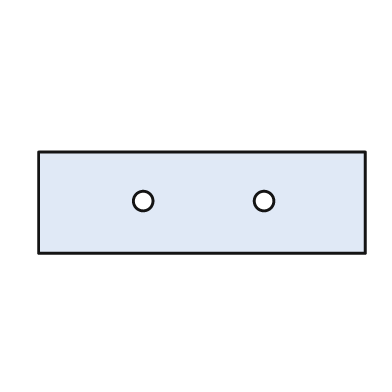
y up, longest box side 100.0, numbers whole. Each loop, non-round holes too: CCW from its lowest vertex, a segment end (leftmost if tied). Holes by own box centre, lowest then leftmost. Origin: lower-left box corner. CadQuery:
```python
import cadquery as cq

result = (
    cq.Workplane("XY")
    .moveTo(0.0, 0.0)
    .lineTo(100.0, 0.0)
    .lineTo(100.0, 31.0)
    .lineTo(0.0, 31.0)
    .close()
    .moveTo(32.0, 16.0)
    .circle(3.0)
    .moveTo(69.0, 16.0)
    .circle(3.0)
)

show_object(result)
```